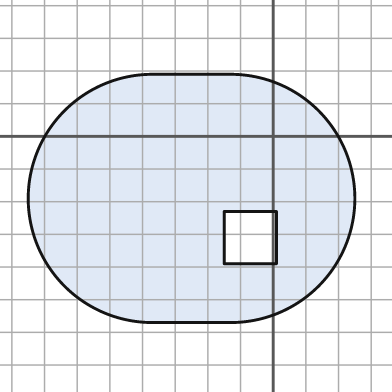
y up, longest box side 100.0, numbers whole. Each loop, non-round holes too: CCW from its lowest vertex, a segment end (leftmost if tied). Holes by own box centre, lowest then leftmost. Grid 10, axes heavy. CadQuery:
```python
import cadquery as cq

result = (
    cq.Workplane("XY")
    .moveTo(-37.0, -57.0)
    .lineTo(-13.0, -57.0)
    .threePointArc((25.0, -19.0), (-13.0, 19.0))
    .lineTo(-37.0, 19.0)
    .threePointArc((-75.0, -19.0), (-37.0, -57.0))
    .close()
    .moveTo(-15.0, -39.0)
    .lineTo(1.0, -39.0)
    .lineTo(1.0, -23.0)
    .lineTo(-15.0, -23.0)
    .close()
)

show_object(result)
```